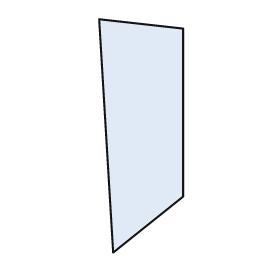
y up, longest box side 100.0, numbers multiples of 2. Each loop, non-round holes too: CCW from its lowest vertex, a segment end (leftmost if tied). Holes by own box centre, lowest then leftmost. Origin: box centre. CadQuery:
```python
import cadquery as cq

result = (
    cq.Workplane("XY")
    .moveTo(-12.0, -50.0)
    .lineTo(18.0, -26.0)
    .lineTo(18.0, 46.0)
    .lineTo(-18.0, 50.0)
    .close()
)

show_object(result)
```